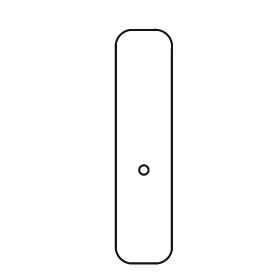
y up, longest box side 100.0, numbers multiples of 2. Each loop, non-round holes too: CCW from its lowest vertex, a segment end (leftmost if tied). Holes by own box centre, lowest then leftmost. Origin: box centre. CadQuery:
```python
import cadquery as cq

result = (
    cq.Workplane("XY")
    .moveTo(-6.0, -50.0)
    .lineTo(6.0, -50.0)
    .threePointArc((10.0, -48.0), (12.0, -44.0))
    .lineTo(12.0, 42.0)
    .threePointArc((10.0, 48.0), (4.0, 50.0))
    .lineTo(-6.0, 50.0)
    .threePointArc((-10.0, 48.0), (-12.0, 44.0))
    .lineTo(-12.0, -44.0)
    .threePointArc((-10.0, -48.0), (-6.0, -50.0))
    .close()
    .moveTo(0.0, -10.0)
    .circle(2.0)
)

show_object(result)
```